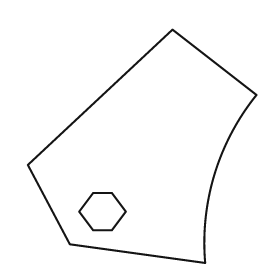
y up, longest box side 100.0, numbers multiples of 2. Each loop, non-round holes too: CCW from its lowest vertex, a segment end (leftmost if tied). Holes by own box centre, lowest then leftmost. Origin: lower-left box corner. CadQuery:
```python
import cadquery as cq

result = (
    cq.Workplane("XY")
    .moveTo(76.0, 0.0)
    .threePointArc((80.0, 38.0), (98.0, 72.0))
    .lineTo(62.0, 100.0)
    .lineTo(0.0, 42.0)
    .lineTo(18.0, 8.0)
    .close()
    .moveTo(28.0, 14.0)
    .lineTo(36.0, 14.0)
    .lineTo(42.0, 22.0)
    .lineTo(36.0, 30.0)
    .lineTo(28.0, 30.0)
    .lineTo(22.0, 22.0)
    .close()
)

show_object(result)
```